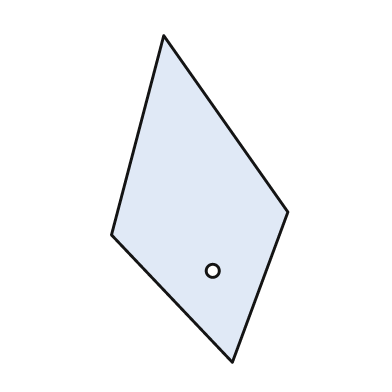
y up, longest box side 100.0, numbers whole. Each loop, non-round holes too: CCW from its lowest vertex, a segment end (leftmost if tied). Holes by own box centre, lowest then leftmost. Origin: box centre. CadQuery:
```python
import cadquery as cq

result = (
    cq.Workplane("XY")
    .moveTo(10.0, -50.0)
    .lineTo(27.0, -4.0)
    .lineTo(-11.0, 50.0)
    .lineTo(-27.0, -11.0)
    .close()
    .moveTo(4.0, -22.0)
    .circle(2.0)
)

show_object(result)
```